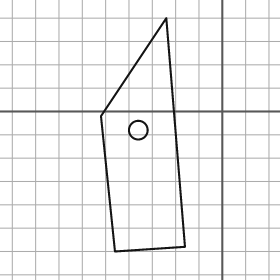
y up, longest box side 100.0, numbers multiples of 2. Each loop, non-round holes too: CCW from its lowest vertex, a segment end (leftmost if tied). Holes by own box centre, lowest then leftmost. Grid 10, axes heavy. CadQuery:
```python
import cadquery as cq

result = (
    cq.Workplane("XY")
    .moveTo(-46.0, -60.0)
    .lineTo(-16.0, -58.0)
    .lineTo(-24.0, 40.0)
    .lineTo(-52.0, -2.0)
    .close()
    .moveTo(-36.0, -8.0)
    .circle(4.0)
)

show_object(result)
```